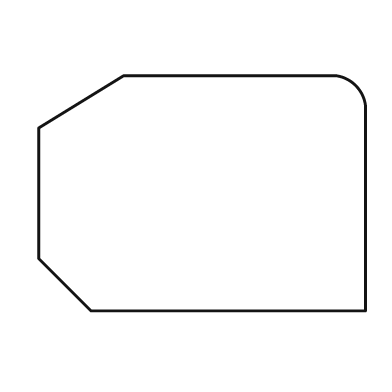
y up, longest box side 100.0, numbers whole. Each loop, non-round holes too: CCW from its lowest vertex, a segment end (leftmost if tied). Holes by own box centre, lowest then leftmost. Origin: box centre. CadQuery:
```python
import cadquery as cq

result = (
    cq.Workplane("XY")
    .moveTo(-34.0, -36.0)
    .lineTo(50.0, -36.0)
    .lineTo(50.0, 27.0)
    .threePointArc((47.0, 33.0), (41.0, 36.0))
    .lineTo(-24.0, 36.0)
    .lineTo(-50.0, 20.0)
    .lineTo(-50.0, -20.0)
    .close()
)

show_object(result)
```